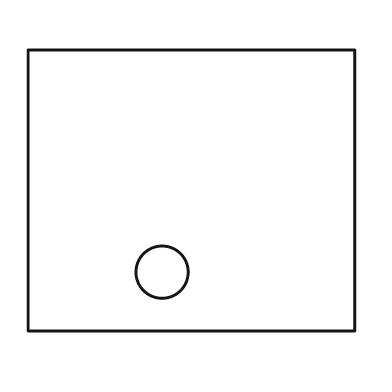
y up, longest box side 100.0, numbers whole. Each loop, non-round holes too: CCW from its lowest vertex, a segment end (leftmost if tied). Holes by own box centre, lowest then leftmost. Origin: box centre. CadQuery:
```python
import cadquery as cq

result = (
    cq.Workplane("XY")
    .moveTo(-50.0, -43.0)
    .lineTo(50.0, -43.0)
    .lineTo(50.0, 43.0)
    .lineTo(-50.0, 43.0)
    .close()
    .moveTo(-9.0, -25.0)
    .circle(8.0)
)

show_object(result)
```